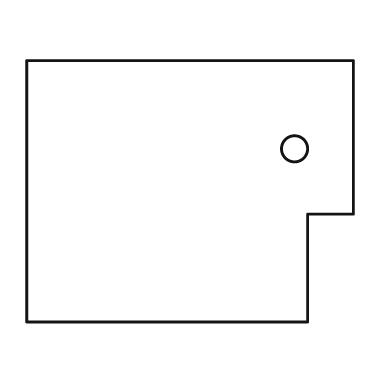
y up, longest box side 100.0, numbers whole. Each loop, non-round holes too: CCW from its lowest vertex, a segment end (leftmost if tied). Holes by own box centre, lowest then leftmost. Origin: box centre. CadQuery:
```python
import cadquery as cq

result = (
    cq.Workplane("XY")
    .moveTo(-50.0, -40.0)
    .lineTo(36.0, -40.0)
    .lineTo(36.0, -7.0)
    .lineTo(50.0, -7.0)
    .lineTo(50.0, 40.0)
    .lineTo(-50.0, 40.0)
    .close()
    .moveTo(32.0, 13.0)
    .circle(4.0)
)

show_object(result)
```